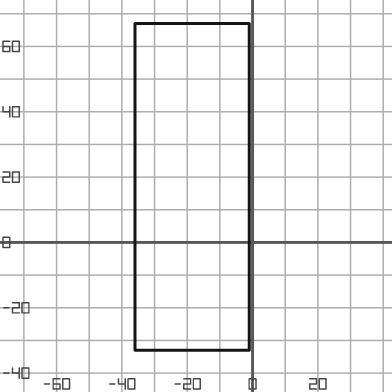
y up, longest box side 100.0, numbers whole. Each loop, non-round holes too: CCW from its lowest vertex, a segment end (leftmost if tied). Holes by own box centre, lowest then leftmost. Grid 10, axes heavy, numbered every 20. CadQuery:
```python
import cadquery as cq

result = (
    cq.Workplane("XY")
    .moveTo(-36.0, -33.0)
    .lineTo(-1.0, -33.0)
    .lineTo(-1.0, 67.0)
    .lineTo(-36.0, 67.0)
    .close()
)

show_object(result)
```